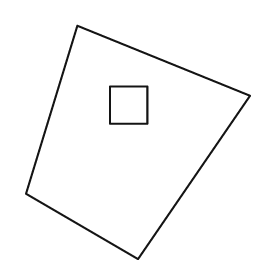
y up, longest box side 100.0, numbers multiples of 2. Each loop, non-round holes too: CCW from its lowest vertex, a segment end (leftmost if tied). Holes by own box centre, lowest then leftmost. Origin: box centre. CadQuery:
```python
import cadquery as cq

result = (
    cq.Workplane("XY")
    .moveTo(0.0, -50.0)
    .lineTo(48.0, 20.0)
    .lineTo(-26.0, 50.0)
    .lineTo(-48.0, -22.0)
    .close()
    .moveTo(-12.0, 8.0)
    .lineTo(4.0, 8.0)
    .lineTo(4.0, 24.0)
    .lineTo(-12.0, 24.0)
    .close()
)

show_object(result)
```